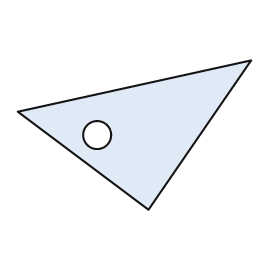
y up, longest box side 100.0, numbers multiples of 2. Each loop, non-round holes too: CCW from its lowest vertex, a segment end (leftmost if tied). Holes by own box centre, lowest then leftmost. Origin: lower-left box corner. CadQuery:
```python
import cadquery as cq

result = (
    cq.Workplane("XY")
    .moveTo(56.0, 0.0)
    .lineTo(100.0, 64.0)
    .lineTo(0.0, 42.0)
    .close()
    .moveTo(34.0, 32.0)
    .circle(6.0)
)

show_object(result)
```